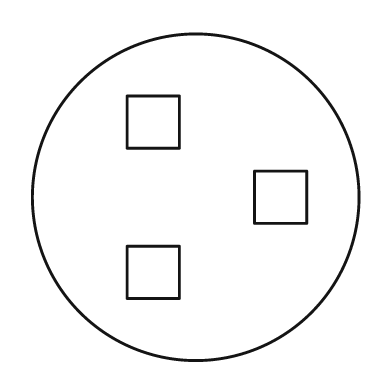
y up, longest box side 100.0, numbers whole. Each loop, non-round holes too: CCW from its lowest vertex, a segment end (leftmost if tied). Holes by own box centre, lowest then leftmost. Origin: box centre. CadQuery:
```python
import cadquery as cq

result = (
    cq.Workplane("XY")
    .moveTo(0.0, 0.0)
    .circle(50.0)
    .moveTo(-21.0, -31.0)
    .lineTo(-5.0, -31.0)
    .lineTo(-5.0, -15.0)
    .lineTo(-21.0, -15.0)
    .close()
    .moveTo(18.0, -8.0)
    .lineTo(34.0, -8.0)
    .lineTo(34.0, 8.0)
    .lineTo(18.0, 8.0)
    .close()
    .moveTo(-21.0, 15.0)
    .lineTo(-5.0, 15.0)
    .lineTo(-5.0, 31.0)
    .lineTo(-21.0, 31.0)
    .close()
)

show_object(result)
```